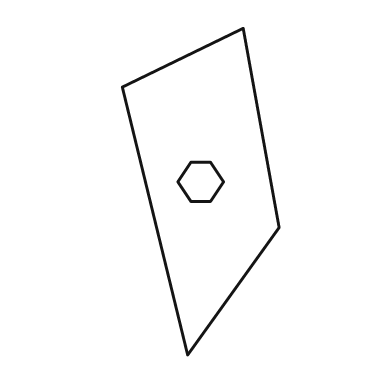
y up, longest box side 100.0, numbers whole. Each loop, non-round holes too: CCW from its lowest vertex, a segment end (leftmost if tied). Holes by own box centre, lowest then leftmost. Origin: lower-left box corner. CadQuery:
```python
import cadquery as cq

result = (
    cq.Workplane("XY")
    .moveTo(20.0, 0.0)
    .lineTo(48.0, 39.0)
    .lineTo(37.0, 100.0)
    .lineTo(0.0, 82.0)
    .close()
    .moveTo(21.0, 47.0)
    .lineTo(27.0, 47.0)
    .lineTo(31.0, 53.0)
    .lineTo(27.0, 59.0)
    .lineTo(21.0, 59.0)
    .lineTo(17.0, 53.0)
    .close()
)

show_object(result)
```